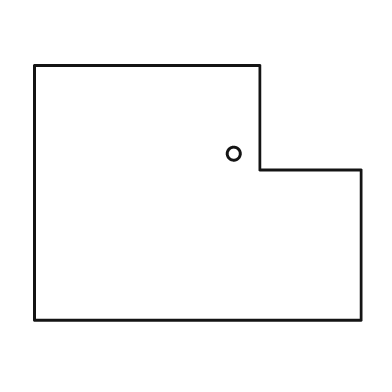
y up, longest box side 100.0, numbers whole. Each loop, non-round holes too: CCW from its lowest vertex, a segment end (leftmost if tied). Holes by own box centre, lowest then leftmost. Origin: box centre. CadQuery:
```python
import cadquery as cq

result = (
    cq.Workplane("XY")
    .moveTo(-50.0, -39.0)
    .lineTo(50.0, -39.0)
    .lineTo(50.0, 7.0)
    .lineTo(19.0, 7.0)
    .lineTo(19.0, 39.0)
    .lineTo(-50.0, 39.0)
    .close()
    .moveTo(11.0, 12.0)
    .circle(2.0)
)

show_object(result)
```